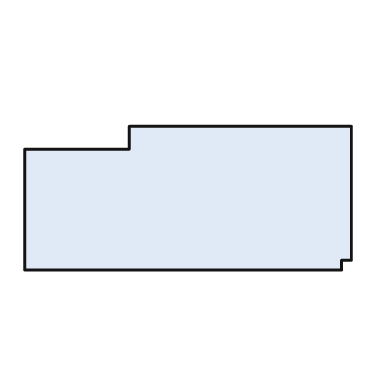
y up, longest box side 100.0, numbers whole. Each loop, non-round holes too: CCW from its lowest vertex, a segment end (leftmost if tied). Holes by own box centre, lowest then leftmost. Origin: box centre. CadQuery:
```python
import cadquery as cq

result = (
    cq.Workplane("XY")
    .moveTo(-50.0, -22.0)
    .lineTo(47.0, -22.0)
    .lineTo(47.0, -19.0)
    .lineTo(50.0, -19.0)
    .lineTo(50.0, 22.0)
    .lineTo(-18.0, 22.0)
    .lineTo(-18.0, 15.0)
    .lineTo(-50.0, 15.0)
    .close()
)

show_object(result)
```